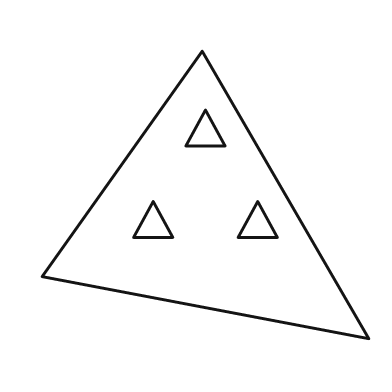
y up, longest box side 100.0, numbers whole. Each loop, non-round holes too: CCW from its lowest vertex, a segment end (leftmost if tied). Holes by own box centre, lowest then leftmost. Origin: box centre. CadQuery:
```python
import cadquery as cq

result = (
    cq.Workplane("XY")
    .moveTo(50.0, -44.0)
    .lineTo(-1.0, 44.0)
    .lineTo(-50.0, -25.0)
    .close()
    .moveTo(-22.0, -13.0)
    .lineTo(-10.0, -13.0)
    .lineTo(-16.0, -2.0)
    .close()
    .moveTo(10.0, -13.0)
    .lineTo(22.0, -13.0)
    .lineTo(16.0, -2.0)
    .close()
    .moveTo(-6.0, 15.0)
    .lineTo(6.0, 15.0)
    .lineTo(0.0, 26.0)
    .close()
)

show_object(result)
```